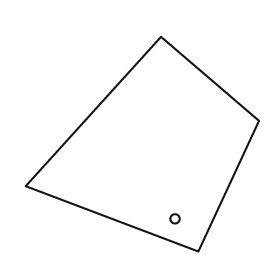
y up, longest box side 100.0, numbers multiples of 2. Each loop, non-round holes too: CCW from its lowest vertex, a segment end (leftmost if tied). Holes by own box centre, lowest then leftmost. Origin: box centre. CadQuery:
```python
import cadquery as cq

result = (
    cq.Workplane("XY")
    .moveTo(24.0, -46.0)
    .lineTo(50.0, 10.0)
    .lineTo(8.0, 46.0)
    .lineTo(-50.0, -18.0)
    .close()
    .moveTo(14.0, -32.0)
    .circle(2.0)
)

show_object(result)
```